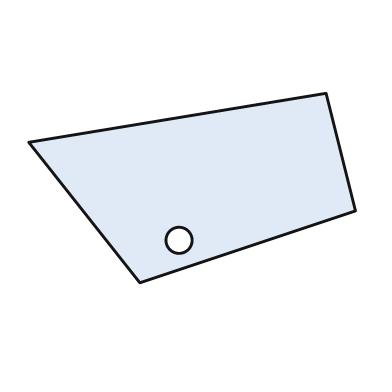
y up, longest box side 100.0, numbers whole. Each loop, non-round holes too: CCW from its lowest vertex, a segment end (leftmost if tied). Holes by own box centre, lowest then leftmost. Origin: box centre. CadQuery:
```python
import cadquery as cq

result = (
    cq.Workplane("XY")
    .moveTo(-16.0, -29.0)
    .lineTo(50.0, -7.0)
    .lineTo(41.0, 29.0)
    .lineTo(-50.0, 14.0)
    .close()
    .moveTo(-4.0, -16.0)
    .circle(4.0)
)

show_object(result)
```